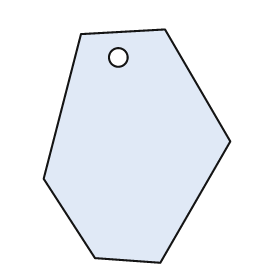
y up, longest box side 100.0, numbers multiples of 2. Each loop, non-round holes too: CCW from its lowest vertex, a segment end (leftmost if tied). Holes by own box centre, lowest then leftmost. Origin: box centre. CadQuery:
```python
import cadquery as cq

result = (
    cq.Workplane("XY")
    .moveTo(10.0, -50.0)
    .lineTo(40.0, 2.0)
    .lineTo(12.0, 50.0)
    .lineTo(-24.0, 48.0)
    .lineTo(-40.0, -14.0)
    .lineTo(-18.0, -48.0)
    .close()
    .moveTo(-8.0, 38.0)
    .circle(4.0)
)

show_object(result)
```